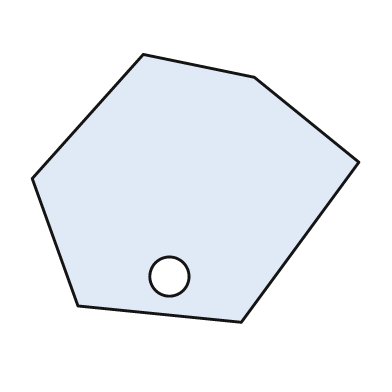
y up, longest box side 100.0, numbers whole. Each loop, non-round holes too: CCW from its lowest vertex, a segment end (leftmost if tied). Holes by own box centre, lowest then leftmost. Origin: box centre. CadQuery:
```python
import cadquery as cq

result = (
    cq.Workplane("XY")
    .moveTo(14.0, -41.0)
    .lineTo(50.0, 8.0)
    .lineTo(18.0, 34.0)
    .lineTo(-16.0, 41.0)
    .lineTo(-50.0, 3.0)
    .lineTo(-36.0, -36.0)
    .close()
    .moveTo(-8.0, -27.0)
    .circle(6.0)
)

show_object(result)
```